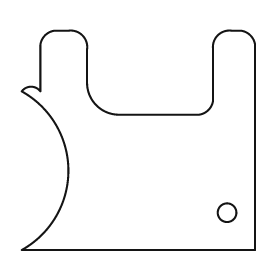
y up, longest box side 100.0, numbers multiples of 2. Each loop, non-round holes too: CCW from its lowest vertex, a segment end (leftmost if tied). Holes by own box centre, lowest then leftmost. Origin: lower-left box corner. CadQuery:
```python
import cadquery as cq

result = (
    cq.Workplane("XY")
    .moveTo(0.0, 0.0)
    .lineTo(100.0, 0.0)
    .lineTo(100.0, 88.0)
    .threePointArc((98.0, 92.0), (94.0, 94.0))
    .lineTo(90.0, 94.0)
    .threePointArc((84.0, 92.0), (82.0, 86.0))
    .lineTo(82.0, 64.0)
    .threePointArc((80.0, 60.0), (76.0, 58.0))
    .lineTo(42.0, 58.0)
    .threePointArc((32.0, 62.0), (28.0, 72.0))
    .lineTo(28.0, 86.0)
    .threePointArc((26.0, 92.0), (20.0, 94.0))
    .lineTo(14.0, 94.0)
    .threePointArc((10.0, 92.0), (8.0, 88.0))
    .lineTo(8.0, 68.0)
    .threePointArc((4.0, 70.0), (0.0, 68.0))
    .threePointArc((20.0, 34.0), (0.0, 0.0))
    .close()
    .moveTo(88.0, 16.0)
    .circle(4.0)
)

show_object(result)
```